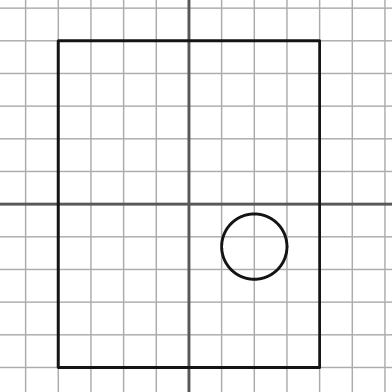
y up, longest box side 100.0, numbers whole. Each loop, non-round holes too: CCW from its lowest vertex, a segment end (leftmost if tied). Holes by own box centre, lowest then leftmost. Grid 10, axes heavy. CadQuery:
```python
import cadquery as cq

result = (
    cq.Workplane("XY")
    .moveTo(-40.0, -50.0)
    .lineTo(40.0, -50.0)
    .lineTo(40.0, 50.0)
    .lineTo(-40.0, 50.0)
    .close()
    .moveTo(20.0, -13.0)
    .circle(10.0)
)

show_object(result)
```